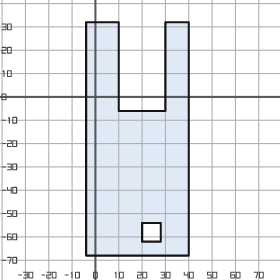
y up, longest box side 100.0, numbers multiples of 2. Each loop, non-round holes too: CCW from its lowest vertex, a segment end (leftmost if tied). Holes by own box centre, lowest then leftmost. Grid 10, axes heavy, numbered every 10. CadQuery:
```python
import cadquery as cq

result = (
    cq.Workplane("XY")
    .moveTo(-4.0, -68.0)
    .lineTo(40.0, -68.0)
    .lineTo(40.0, 32.0)
    .lineTo(30.0, 32.0)
    .lineTo(30.0, -6.0)
    .lineTo(10.0, -6.0)
    .lineTo(10.0, 32.0)
    .lineTo(-4.0, 32.0)
    .close()
    .moveTo(20.0, -62.0)
    .lineTo(28.0, -62.0)
    .lineTo(28.0, -54.0)
    .lineTo(20.0, -54.0)
    .close()
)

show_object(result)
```